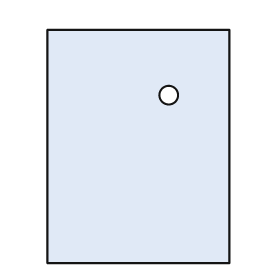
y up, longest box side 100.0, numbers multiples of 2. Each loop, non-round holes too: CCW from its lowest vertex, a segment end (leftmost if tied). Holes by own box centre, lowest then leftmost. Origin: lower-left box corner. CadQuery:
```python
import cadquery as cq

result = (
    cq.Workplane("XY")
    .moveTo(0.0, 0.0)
    .lineTo(78.0, 0.0)
    .lineTo(78.0, 100.0)
    .lineTo(0.0, 100.0)
    .close()
    .moveTo(52.0, 72.0)
    .circle(4.0)
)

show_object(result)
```